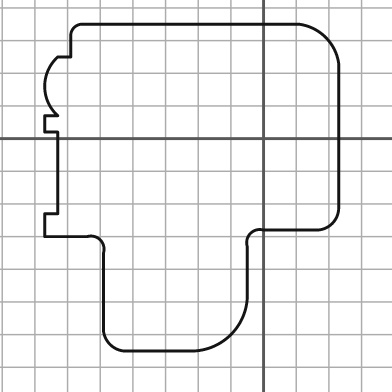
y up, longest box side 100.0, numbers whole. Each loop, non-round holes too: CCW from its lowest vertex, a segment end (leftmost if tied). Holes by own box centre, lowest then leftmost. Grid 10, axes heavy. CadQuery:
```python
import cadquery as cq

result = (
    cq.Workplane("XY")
    .moveTo(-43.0, -65.0)
    .lineTo(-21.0, -65.0)
    .threePointArc((-10.0, -60.0), (-5.0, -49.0))
    .lineTo(-5.0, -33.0)
    .threePointArc((-4.0, -29.0), (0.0, -28.0))
    .lineTo(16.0, -28.0)
    .threePointArc((21.0, -26.0), (23.0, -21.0))
    .lineTo(23.0, 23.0)
    .threePointArc((19.0, 31.0), (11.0, 35.0))
    .lineTo(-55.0, 35.0)
    .threePointArc((-58.0, 34.0), (-59.0, 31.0))
    .lineTo(-59.0, 25.0)
    .lineTo(-63.0, 25.0)
    .threePointArc((-67.0, 16.0), (-63.0, 7.0))
    .lineTo(-67.0, 7.0)
    .lineTo(-67.0, 2.0)
    .lineTo(-63.0, 2.0)
    .lineTo(-63.0, -23.0)
    .lineTo(-67.0, -23.0)
    .lineTo(-67.0, -30.0)
    .lineTo(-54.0, -30.0)
    .threePointArc((-50.0, -31.0), (-49.0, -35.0))
    .lineTo(-49.0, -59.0)
    .threePointArc((-47.0, -63.0), (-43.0, -65.0))
    .close()
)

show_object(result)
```